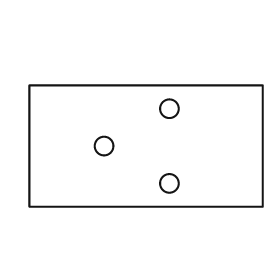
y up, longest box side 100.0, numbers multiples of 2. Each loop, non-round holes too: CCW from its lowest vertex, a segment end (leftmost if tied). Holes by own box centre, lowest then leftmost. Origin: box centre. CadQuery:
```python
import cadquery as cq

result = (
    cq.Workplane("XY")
    .moveTo(-50.0, -26.0)
    .lineTo(50.0, -26.0)
    .lineTo(50.0, 26.0)
    .lineTo(-50.0, 26.0)
    .close()
    .moveTo(10.0, -16.0)
    .circle(4.0)
    .moveTo(-18.0, 0.0)
    .circle(4.0)
    .moveTo(10.0, 16.0)
    .circle(4.0)
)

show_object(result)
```